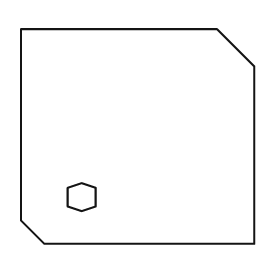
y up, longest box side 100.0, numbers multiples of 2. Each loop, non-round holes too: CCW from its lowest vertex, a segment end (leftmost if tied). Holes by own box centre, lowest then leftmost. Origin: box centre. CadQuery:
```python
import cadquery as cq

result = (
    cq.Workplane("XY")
    .moveTo(-40.0, -46.0)
    .lineTo(50.0, -46.0)
    .lineTo(50.0, 30.0)
    .lineTo(34.0, 46.0)
    .lineTo(-50.0, 46.0)
    .lineTo(-50.0, -36.0)
    .close()
    .moveTo(-24.0, -32.0)
    .lineTo(-18.0, -30.0)
    .lineTo(-18.0, -22.0)
    .lineTo(-24.0, -20.0)
    .lineTo(-30.0, -22.0)
    .lineTo(-30.0, -30.0)
    .close()
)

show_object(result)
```